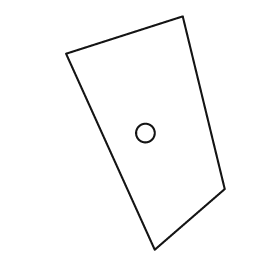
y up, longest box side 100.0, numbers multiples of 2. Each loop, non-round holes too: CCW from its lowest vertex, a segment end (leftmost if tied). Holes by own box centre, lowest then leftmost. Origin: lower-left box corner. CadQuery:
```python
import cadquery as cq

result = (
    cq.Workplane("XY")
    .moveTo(38.0, 0.0)
    .lineTo(68.0, 26.0)
    .lineTo(50.0, 100.0)
    .lineTo(0.0, 84.0)
    .close()
    .moveTo(34.0, 50.0)
    .circle(4.0)
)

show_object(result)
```